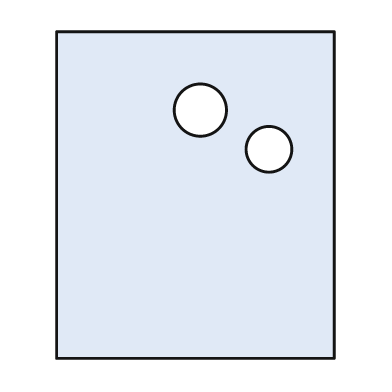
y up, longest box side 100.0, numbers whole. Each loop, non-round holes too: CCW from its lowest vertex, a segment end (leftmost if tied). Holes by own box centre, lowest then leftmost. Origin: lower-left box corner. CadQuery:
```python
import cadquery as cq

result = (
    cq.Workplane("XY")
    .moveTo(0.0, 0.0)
    .lineTo(85.0, 0.0)
    .lineTo(85.0, 100.0)
    .lineTo(0.0, 100.0)
    .close()
    .moveTo(65.0, 64.0)
    .circle(7.0)
    .moveTo(44.0, 76.0)
    .circle(8.0)
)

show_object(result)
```